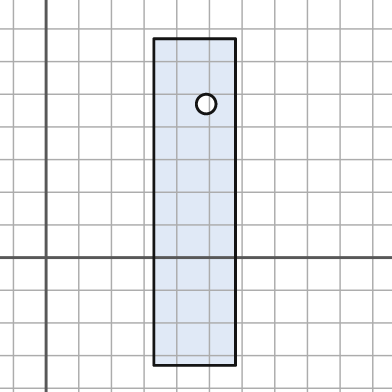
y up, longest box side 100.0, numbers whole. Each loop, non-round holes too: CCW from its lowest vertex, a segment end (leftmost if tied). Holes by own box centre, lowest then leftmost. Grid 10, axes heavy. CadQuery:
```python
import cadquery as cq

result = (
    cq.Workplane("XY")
    .moveTo(33.0, -33.0)
    .lineTo(58.0, -33.0)
    .lineTo(58.0, 67.0)
    .lineTo(33.0, 67.0)
    .close()
    .moveTo(49.0, 47.0)
    .circle(3.0)
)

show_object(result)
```